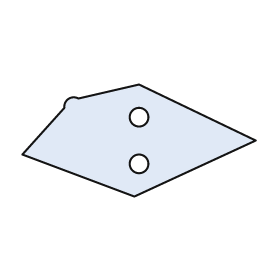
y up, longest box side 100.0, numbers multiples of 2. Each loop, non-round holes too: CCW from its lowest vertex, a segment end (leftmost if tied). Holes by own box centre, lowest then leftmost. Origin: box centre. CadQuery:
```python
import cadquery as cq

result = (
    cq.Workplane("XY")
    .moveTo(-2.0, -24.0)
    .lineTo(50.0, 0.0)
    .lineTo(0.0, 24.0)
    .lineTo(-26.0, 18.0)
    .threePointArc((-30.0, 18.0), (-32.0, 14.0))
    .lineTo(-50.0, -6.0)
    .close()
    .moveTo(0.0, -10.0)
    .circle(4.0)
    .moveTo(0.0, 10.0)
    .circle(4.0)
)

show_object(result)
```